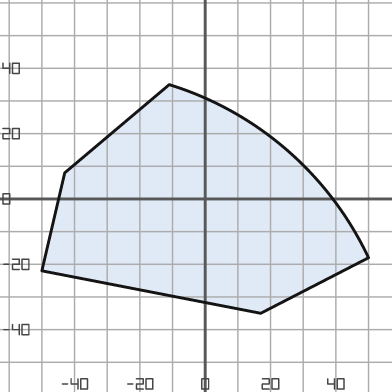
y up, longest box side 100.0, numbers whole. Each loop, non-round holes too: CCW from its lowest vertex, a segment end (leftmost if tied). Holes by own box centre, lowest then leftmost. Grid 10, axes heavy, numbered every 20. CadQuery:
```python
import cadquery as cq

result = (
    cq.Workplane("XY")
    .moveTo(17.0, -35.0)
    .lineTo(50.0, -18.0)
    .threePointArc((25.0, 15.0), (-11.0, 35.0))
    .lineTo(-43.0, 8.0)
    .lineTo(-50.0, -22.0)
    .close()
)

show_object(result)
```